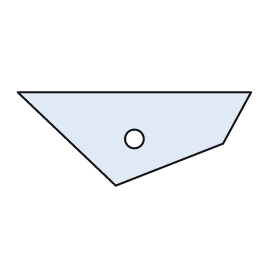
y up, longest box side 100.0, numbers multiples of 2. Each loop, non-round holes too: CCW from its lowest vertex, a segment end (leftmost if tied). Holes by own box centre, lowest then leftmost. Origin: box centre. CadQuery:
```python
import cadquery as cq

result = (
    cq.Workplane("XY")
    .moveTo(-8.0, -20.0)
    .lineTo(38.0, -2.0)
    .lineTo(50.0, 20.0)
    .lineTo(-50.0, 20.0)
    .close()
    .moveTo(0.0, 0.0)
    .circle(4.0)
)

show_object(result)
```